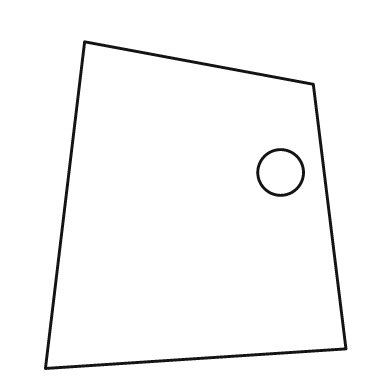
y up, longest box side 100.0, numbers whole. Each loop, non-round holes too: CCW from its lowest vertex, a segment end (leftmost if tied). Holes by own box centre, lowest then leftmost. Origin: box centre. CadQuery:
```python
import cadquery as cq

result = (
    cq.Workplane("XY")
    .moveTo(-46.0, -50.0)
    .lineTo(46.0, -44.0)
    .lineTo(36.0, 37.0)
    .lineTo(-34.0, 50.0)
    .close()
    .moveTo(26.0, 10.0)
    .circle(7.0)
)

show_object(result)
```